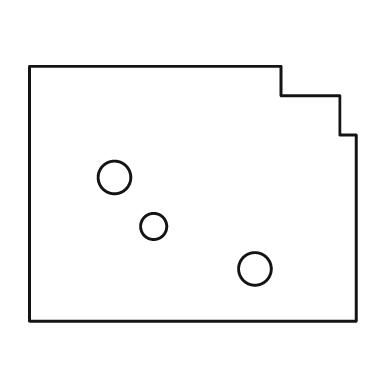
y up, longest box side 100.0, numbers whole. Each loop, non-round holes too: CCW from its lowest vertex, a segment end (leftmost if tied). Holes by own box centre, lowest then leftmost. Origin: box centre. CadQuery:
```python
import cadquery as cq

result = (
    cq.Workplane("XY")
    .moveTo(-50.0, -39.0)
    .lineTo(50.0, -39.0)
    .lineTo(50.0, 18.0)
    .lineTo(45.0, 18.0)
    .lineTo(45.0, 30.0)
    .lineTo(27.0, 30.0)
    .lineTo(27.0, 39.0)
    .lineTo(-50.0, 39.0)
    .close()
    .moveTo(19.0, -23.0)
    .circle(5.0)
    .moveTo(-12.0, -10.0)
    .circle(4.0)
    .moveTo(-24.0, 5.0)
    .circle(5.0)
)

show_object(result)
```